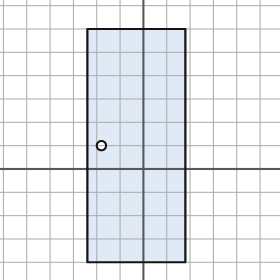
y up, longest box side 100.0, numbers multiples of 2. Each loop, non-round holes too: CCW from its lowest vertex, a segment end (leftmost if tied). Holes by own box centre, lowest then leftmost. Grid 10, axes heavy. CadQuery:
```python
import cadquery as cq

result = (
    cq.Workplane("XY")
    .moveTo(-24.0, -40.0)
    .lineTo(18.0, -40.0)
    .lineTo(18.0, 60.0)
    .lineTo(-24.0, 60.0)
    .close()
    .moveTo(-18.0, 10.0)
    .circle(2.0)
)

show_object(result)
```